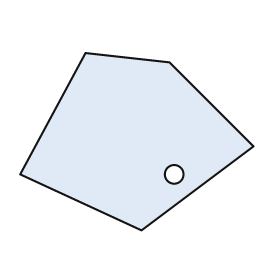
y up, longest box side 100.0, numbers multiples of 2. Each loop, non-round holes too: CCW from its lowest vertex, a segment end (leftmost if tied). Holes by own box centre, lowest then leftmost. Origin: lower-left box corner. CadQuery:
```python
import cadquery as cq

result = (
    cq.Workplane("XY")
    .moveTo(52.0, 0.0)
    .lineTo(100.0, 36.0)
    .lineTo(64.0, 72.0)
    .lineTo(28.0, 76.0)
    .lineTo(0.0, 24.0)
    .close()
    .moveTo(66.0, 24.0)
    .circle(4.0)
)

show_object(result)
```